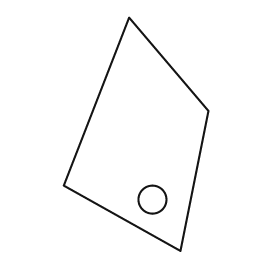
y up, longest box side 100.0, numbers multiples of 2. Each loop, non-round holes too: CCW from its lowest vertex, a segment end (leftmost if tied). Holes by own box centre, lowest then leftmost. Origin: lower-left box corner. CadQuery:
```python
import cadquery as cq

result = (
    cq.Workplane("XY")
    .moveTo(50.0, 0.0)
    .lineTo(62.0, 60.0)
    .lineTo(28.0, 100.0)
    .lineTo(0.0, 28.0)
    .close()
    .moveTo(38.0, 22.0)
    .circle(6.0)
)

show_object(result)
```